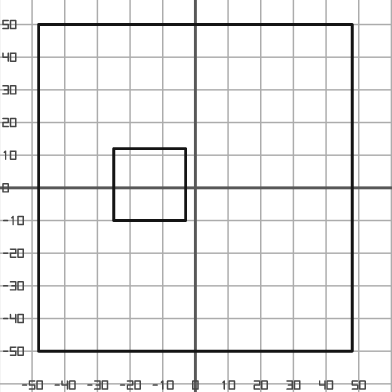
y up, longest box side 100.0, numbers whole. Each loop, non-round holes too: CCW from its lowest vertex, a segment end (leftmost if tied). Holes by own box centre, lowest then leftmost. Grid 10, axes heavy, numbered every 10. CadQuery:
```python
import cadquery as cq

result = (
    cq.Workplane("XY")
    .moveTo(-48.0, -50.0)
    .lineTo(48.0, -50.0)
    .lineTo(48.0, 50.0)
    .lineTo(-48.0, 50.0)
    .close()
    .moveTo(-25.0, -10.0)
    .lineTo(-3.0, -10.0)
    .lineTo(-3.0, 12.0)
    .lineTo(-25.0, 12.0)
    .close()
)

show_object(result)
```